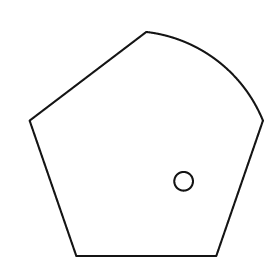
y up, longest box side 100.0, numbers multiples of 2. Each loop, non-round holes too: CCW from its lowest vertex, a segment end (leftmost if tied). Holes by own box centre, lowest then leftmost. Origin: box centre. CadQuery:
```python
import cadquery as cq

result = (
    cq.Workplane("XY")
    .moveTo(-30.0, -48.0)
    .lineTo(30.0, -48.0)
    .lineTo(50.0, 10.0)
    .threePointArc((30.0, 36.0), (0.0, 48.0))
    .lineTo(-50.0, 10.0)
    .close()
    .moveTo(16.0, -16.0)
    .circle(4.0)
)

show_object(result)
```